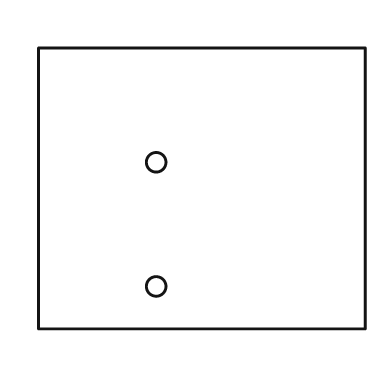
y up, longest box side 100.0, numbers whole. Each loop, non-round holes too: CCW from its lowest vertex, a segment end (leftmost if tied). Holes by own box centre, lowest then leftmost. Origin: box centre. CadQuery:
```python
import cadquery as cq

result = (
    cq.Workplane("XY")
    .moveTo(-50.0, -43.0)
    .lineTo(50.0, -43.0)
    .lineTo(50.0, 43.0)
    .lineTo(-50.0, 43.0)
    .close()
    .moveTo(-14.0, -30.0)
    .circle(3.0)
    .moveTo(-14.0, 8.0)
    .circle(3.0)
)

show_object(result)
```